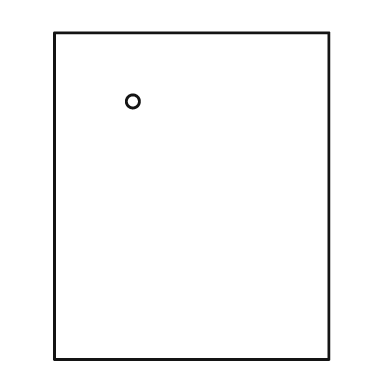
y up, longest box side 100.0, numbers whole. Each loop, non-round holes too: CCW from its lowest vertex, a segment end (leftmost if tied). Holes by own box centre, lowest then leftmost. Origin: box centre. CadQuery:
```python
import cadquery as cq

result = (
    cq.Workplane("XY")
    .moveTo(-42.0, -50.0)
    .lineTo(42.0, -50.0)
    .lineTo(42.0, 50.0)
    .lineTo(-42.0, 50.0)
    .close()
    .moveTo(-18.0, 29.0)
    .circle(2.0)
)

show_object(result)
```